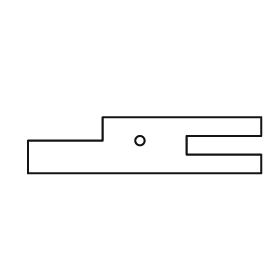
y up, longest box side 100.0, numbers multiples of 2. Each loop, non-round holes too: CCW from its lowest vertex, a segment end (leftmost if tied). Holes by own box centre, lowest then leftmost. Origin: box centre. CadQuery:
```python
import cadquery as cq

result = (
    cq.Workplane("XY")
    .moveTo(-50.0, -12.0)
    .lineTo(50.0, -12.0)
    .lineTo(50.0, -4.0)
    .lineTo(18.0, -4.0)
    .lineTo(18.0, 4.0)
    .lineTo(50.0, 4.0)
    .lineTo(50.0, 12.0)
    .lineTo(-18.0, 12.0)
    .lineTo(-18.0, 2.0)
    .lineTo(-50.0, 2.0)
    .close()
    .moveTo(-2.0, 2.0)
    .circle(2.0)
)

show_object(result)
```